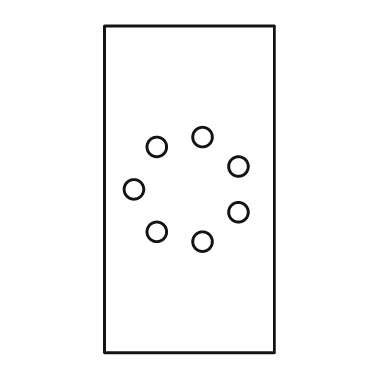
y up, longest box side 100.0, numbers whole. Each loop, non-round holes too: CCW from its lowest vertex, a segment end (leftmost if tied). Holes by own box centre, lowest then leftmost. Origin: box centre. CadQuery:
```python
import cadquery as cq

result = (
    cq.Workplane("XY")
    .moveTo(-26.0, -50.0)
    .lineTo(26.0, -50.0)
    .lineTo(26.0, 50.0)
    .lineTo(-26.0, 50.0)
    .close()
    .moveTo(4.0, -16.0)
    .circle(3.0)
    .moveTo(-10.0, -13.0)
    .circle(3.0)
    .moveTo(15.0, -7.0)
    .circle(3.0)
    .moveTo(-17.0, 0.0)
    .circle(3.0)
    .moveTo(15.0, 7.0)
    .circle(3.0)
    .moveTo(-10.0, 13.0)
    .circle(3.0)
    .moveTo(4.0, 16.0)
    .circle(3.0)
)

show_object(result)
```